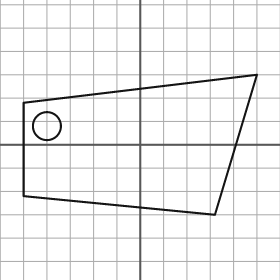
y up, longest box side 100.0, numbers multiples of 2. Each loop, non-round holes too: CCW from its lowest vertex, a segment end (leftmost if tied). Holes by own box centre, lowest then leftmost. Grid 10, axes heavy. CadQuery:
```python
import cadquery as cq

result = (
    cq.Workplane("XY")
    .moveTo(32.0, -30.0)
    .lineTo(50.0, 30.0)
    .lineTo(-50.0, 18.0)
    .lineTo(-50.0, -22.0)
    .close()
    .moveTo(-40.0, 8.0)
    .circle(6.0)
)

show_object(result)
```